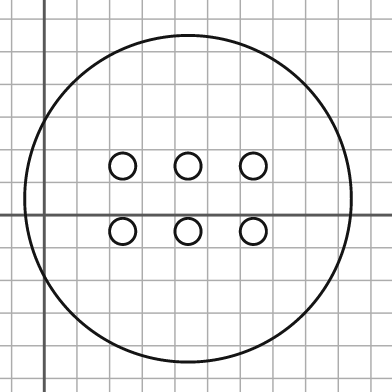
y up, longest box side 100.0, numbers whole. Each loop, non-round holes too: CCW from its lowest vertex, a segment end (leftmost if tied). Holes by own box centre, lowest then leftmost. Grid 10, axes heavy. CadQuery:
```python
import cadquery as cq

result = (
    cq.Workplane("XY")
    .moveTo(44.0, 5.0)
    .circle(50.0)
    .moveTo(24.0, -5.0)
    .circle(4.0)
    .moveTo(44.0, -5.0)
    .circle(4.0)
    .moveTo(64.0, -5.0)
    .circle(4.0)
    .moveTo(24.0, 15.0)
    .circle(4.0)
    .moveTo(44.0, 15.0)
    .circle(4.0)
    .moveTo(64.0, 15.0)
    .circle(4.0)
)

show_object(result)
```